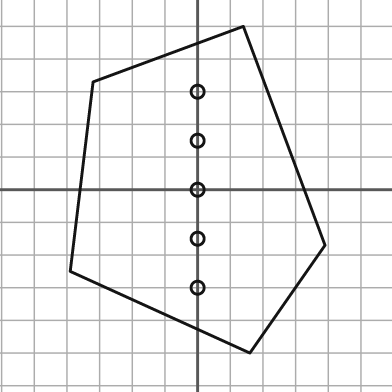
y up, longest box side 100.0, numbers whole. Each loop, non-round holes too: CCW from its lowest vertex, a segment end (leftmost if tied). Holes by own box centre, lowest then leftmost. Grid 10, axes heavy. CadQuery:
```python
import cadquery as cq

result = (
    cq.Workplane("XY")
    .moveTo(16.0, -50.0)
    .lineTo(39.0, -17.0)
    .lineTo(14.0, 50.0)
    .lineTo(-32.0, 33.0)
    .lineTo(-39.0, -25.0)
    .close()
    .moveTo(0.0, -30.0)
    .circle(2.0)
    .moveTo(0.0, -15.0)
    .circle(2.0)
    .moveTo(0.0, 0.0)
    .circle(2.0)
    .moveTo(0.0, 15.0)
    .circle(2.0)
    .moveTo(0.0, 30.0)
    .circle(2.0)
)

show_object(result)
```